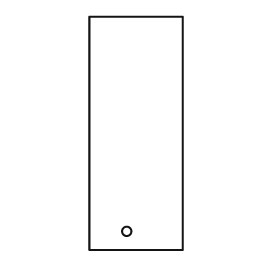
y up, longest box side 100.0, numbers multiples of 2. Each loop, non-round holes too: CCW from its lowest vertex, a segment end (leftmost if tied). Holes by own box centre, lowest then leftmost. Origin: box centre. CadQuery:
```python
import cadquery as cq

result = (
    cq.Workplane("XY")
    .moveTo(-20.0, -50.0)
    .lineTo(20.0, -50.0)
    .lineTo(20.0, 50.0)
    .lineTo(-20.0, 50.0)
    .close()
    .moveTo(-4.0, -42.0)
    .circle(2.0)
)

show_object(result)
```